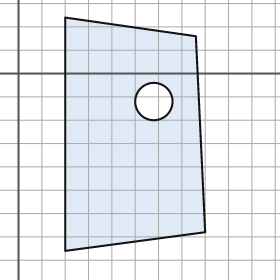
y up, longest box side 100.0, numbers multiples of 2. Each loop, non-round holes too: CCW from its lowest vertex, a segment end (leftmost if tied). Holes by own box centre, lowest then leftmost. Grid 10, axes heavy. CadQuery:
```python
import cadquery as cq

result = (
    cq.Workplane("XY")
    .moveTo(20.0, -76.0)
    .lineTo(80.0, -68.0)
    .lineTo(76.0, 16.0)
    .lineTo(20.0, 24.0)
    .close()
    .moveTo(58.0, -12.0)
    .circle(8.0)
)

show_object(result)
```